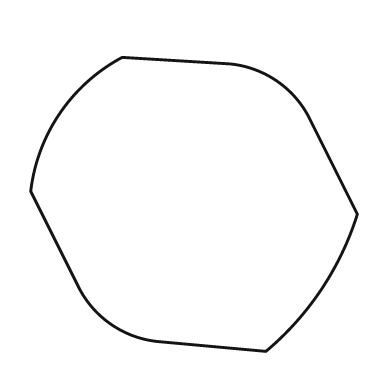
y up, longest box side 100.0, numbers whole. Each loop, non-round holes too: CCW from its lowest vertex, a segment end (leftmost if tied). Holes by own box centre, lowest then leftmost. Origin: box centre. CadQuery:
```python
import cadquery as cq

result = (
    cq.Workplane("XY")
    .moveTo(22.0, -45.0)
    .threePointArc((39.0, -26.0), (50.0, -3.0))
    .lineTo(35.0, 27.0)
    .threePointArc((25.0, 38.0), (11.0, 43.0))
    .lineTo(-22.0, 45.0)
    .threePointArc((-41.0, 28.0), (-50.0, 4.0))
    .lineTo(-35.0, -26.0)
    .threePointArc((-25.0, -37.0), (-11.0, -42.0))
    .close()
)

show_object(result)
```